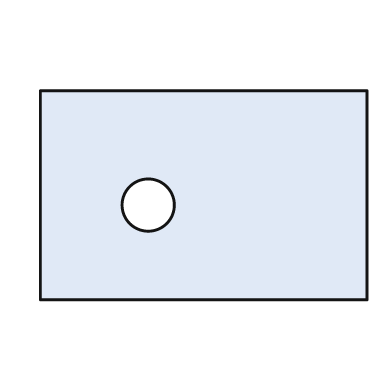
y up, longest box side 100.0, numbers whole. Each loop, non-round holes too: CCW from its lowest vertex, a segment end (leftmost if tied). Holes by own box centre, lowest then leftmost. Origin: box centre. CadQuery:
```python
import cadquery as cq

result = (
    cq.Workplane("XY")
    .moveTo(-50.0, -32.0)
    .lineTo(50.0, -32.0)
    .lineTo(50.0, 32.0)
    .lineTo(-50.0, 32.0)
    .close()
    .moveTo(-17.0, -3.0)
    .circle(8.0)
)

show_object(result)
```